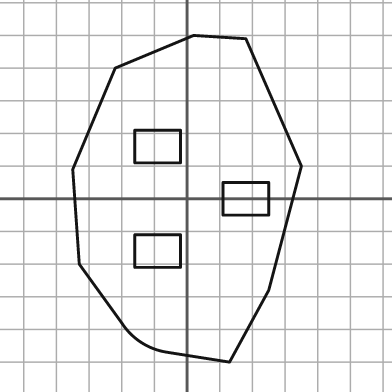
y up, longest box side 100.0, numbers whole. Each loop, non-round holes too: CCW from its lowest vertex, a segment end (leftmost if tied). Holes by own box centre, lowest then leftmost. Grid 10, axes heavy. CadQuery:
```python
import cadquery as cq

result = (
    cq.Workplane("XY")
    .moveTo(13.0, -50.0)
    .lineTo(25.0, -28.0)
    .lineTo(35.0, 10.0)
    .lineTo(18.0, 49.0)
    .lineTo(2.0, 50.0)
    .lineTo(-22.0, 40.0)
    .lineTo(-35.0, 9.0)
    .lineTo(-33.0, -20.0)
    .lineTo(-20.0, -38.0)
    .threePointArc((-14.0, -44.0), (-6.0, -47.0))
    .close()
    .moveTo(-16.0, -21.0)
    .lineTo(-2.0, -21.0)
    .lineTo(-2.0, -11.0)
    .lineTo(-16.0, -11.0)
    .close()
    .moveTo(11.0, -5.0)
    .lineTo(25.0, -5.0)
    .lineTo(25.0, 5.0)
    .lineTo(11.0, 5.0)
    .close()
    .moveTo(-16.0, 11.0)
    .lineTo(-2.0, 11.0)
    .lineTo(-2.0, 21.0)
    .lineTo(-16.0, 21.0)
    .close()
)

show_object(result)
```